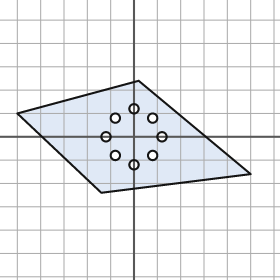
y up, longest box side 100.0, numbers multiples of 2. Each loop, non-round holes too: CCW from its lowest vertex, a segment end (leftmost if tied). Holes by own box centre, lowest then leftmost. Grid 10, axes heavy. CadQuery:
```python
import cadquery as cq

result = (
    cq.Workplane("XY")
    .moveTo(-14.0, -24.0)
    .lineTo(50.0, -16.0)
    .lineTo(2.0, 24.0)
    .lineTo(-50.0, 10.0)
    .close()
    .moveTo(0.0, -12.0)
    .circle(2.0)
    .moveTo(-8.0, -8.0)
    .circle(2.0)
    .moveTo(8.0, -8.0)
    .circle(2.0)
    .moveTo(-12.0, 0.0)
    .circle(2.0)
    .moveTo(12.0, 0.0)
    .circle(2.0)
    .moveTo(-8.0, 8.0)
    .circle(2.0)
    .moveTo(8.0, 8.0)
    .circle(2.0)
    .moveTo(0.0, 12.0)
    .circle(2.0)
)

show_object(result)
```